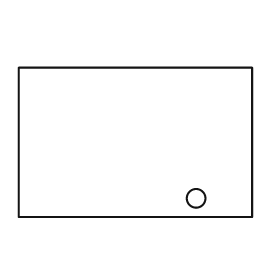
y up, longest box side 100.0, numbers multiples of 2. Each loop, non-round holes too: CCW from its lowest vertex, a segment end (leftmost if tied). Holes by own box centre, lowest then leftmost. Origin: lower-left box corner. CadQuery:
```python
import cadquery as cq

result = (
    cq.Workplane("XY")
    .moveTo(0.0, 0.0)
    .lineTo(100.0, 0.0)
    .lineTo(100.0, 64.0)
    .lineTo(0.0, 64.0)
    .close()
    .moveTo(76.0, 8.0)
    .circle(4.0)
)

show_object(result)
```